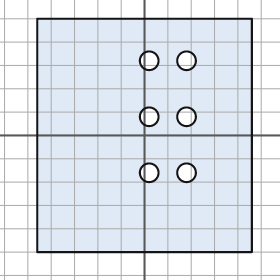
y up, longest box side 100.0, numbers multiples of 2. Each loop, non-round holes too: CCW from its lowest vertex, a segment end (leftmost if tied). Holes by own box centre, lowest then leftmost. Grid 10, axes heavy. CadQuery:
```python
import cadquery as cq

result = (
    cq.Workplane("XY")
    .moveTo(-46.0, -50.0)
    .lineTo(46.0, -50.0)
    .lineTo(46.0, 50.0)
    .lineTo(-46.0, 50.0)
    .close()
    .moveTo(2.0, -16.0)
    .circle(4.0)
    .moveTo(18.0, -16.0)
    .circle(4.0)
    .moveTo(2.0, 8.0)
    .circle(4.0)
    .moveTo(18.0, 8.0)
    .circle(4.0)
    .moveTo(2.0, 32.0)
    .circle(4.0)
    .moveTo(18.0, 32.0)
    .circle(4.0)
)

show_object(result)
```